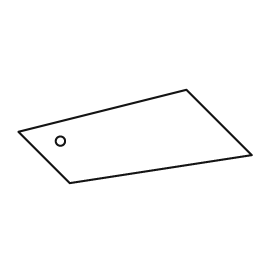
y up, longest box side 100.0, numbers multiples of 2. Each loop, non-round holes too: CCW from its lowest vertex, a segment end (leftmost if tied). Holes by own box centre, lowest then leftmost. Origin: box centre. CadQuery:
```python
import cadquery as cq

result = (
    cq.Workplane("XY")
    .moveTo(-28.0, -20.0)
    .lineTo(50.0, -8.0)
    .lineTo(22.0, 20.0)
    .lineTo(-50.0, 2.0)
    .close()
    .moveTo(-32.0, -2.0)
    .circle(2.0)
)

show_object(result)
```